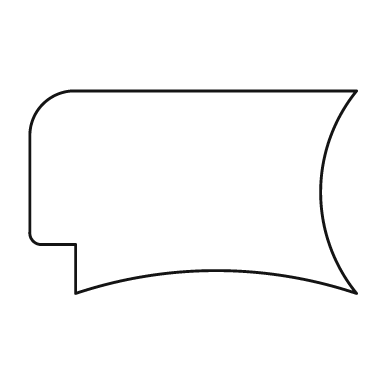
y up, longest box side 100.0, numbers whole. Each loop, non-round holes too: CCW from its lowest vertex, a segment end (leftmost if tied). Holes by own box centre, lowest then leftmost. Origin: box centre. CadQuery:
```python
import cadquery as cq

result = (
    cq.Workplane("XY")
    .moveTo(-36.0, -31.0)
    .threePointArc((7.0, -24.0), (50.0, -31.0))
    .threePointArc((39.0, 0.0), (50.0, 31.0))
    .lineTo(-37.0, 31.0)
    .threePointArc((-46.0, 27.0), (-50.0, 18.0))
    .lineTo(-50.0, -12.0)
    .threePointArc((-49.0, -15.0), (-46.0, -16.0))
    .lineTo(-36.0, -16.0)
    .close()
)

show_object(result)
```